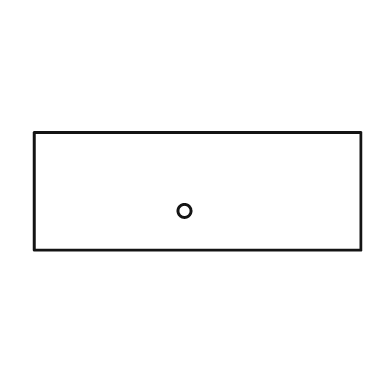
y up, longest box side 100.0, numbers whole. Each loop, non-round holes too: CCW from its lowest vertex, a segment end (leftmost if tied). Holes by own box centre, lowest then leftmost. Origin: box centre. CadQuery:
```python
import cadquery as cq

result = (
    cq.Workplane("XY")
    .moveTo(-50.0, -18.0)
    .lineTo(50.0, -18.0)
    .lineTo(50.0, 18.0)
    .lineTo(-50.0, 18.0)
    .close()
    .moveTo(-4.0, -6.0)
    .circle(2.0)
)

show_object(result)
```